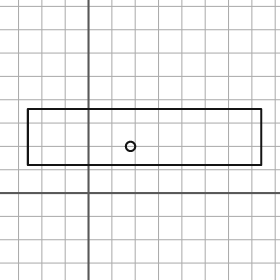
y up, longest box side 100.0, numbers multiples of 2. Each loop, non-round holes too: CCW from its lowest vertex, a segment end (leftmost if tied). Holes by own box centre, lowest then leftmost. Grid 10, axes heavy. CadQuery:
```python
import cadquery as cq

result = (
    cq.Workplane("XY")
    .moveTo(-26.0, 12.0)
    .lineTo(74.0, 12.0)
    .lineTo(74.0, 36.0)
    .lineTo(-26.0, 36.0)
    .close()
    .moveTo(18.0, 20.0)
    .circle(2.0)
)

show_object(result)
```